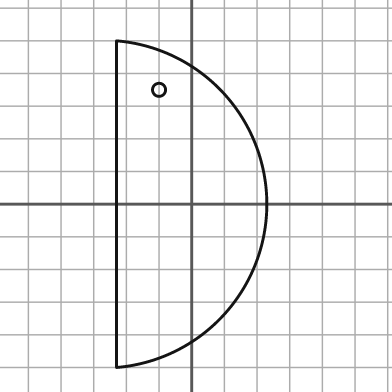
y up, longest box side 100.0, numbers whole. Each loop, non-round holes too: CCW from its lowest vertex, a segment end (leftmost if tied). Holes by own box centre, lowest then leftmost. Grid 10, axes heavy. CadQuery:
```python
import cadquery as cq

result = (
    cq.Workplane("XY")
    .moveTo(-23.0, -50.0)
    .threePointArc((23.0, 0.0), (-23.0, 50.0))
    .close()
    .moveTo(-10.0, 35.0)
    .circle(2.0)
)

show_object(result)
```